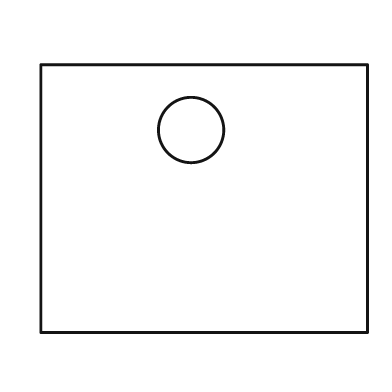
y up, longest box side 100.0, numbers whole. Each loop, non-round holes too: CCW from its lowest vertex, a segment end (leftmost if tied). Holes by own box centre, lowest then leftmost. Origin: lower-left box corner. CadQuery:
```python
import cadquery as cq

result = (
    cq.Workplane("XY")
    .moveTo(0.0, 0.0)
    .lineTo(100.0, 0.0)
    .lineTo(100.0, 82.0)
    .lineTo(0.0, 82.0)
    .close()
    .moveTo(46.0, 62.0)
    .circle(10.0)
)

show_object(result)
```